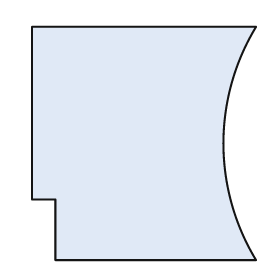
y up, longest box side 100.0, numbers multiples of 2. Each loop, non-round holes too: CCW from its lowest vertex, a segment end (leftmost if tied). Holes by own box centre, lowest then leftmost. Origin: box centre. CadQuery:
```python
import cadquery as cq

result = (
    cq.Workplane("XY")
    .moveTo(-38.0, -50.0)
    .lineTo(48.0, -50.0)
    .threePointArc((34.0, 0.0), (48.0, 50.0))
    .lineTo(-48.0, 50.0)
    .lineTo(-48.0, -24.0)
    .lineTo(-38.0, -24.0)
    .close()
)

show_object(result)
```